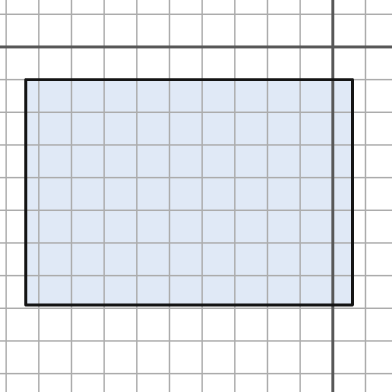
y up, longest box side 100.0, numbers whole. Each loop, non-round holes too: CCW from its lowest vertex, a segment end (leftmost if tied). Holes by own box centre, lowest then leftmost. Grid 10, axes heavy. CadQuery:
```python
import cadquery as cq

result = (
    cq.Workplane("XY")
    .moveTo(-94.0, -79.0)
    .lineTo(6.0, -79.0)
    .lineTo(6.0, -10.0)
    .lineTo(-94.0, -10.0)
    .close()
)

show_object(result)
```